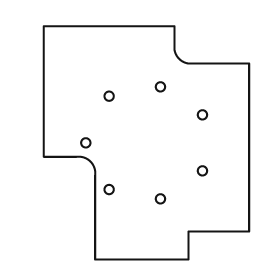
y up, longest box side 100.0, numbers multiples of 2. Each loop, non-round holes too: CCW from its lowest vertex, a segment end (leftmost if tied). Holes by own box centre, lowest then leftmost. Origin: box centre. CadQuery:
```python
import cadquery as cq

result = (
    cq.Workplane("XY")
    .moveTo(-22.0, -50.0)
    .lineTo(18.0, -50.0)
    .lineTo(18.0, -38.0)
    .lineTo(44.0, -38.0)
    .lineTo(44.0, 34.0)
    .lineTo(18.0, 34.0)
    .threePointArc((14.0, 36.0), (12.0, 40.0))
    .lineTo(12.0, 50.0)
    .lineTo(-44.0, 50.0)
    .lineTo(-44.0, -6.0)
    .lineTo(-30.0, -6.0)
    .threePointArc((-24.0, -8.0), (-22.0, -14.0))
    .close()
    .moveTo(6.0, -24.0)
    .circle(2.0)
    .moveTo(-16.0, -20.0)
    .circle(2.0)
    .moveTo(24.0, -12.0)
    .circle(2.0)
    .moveTo(-26.0, 0.0)
    .circle(2.0)
    .moveTo(24.0, 12.0)
    .circle(2.0)
    .moveTo(-16.0, 20.0)
    .circle(2.0)
    .moveTo(6.0, 24.0)
    .circle(2.0)
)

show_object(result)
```